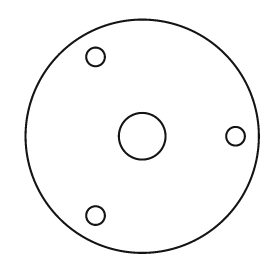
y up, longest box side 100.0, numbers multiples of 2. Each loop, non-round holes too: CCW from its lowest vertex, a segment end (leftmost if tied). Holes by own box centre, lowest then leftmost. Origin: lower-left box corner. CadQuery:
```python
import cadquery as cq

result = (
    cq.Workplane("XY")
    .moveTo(50.0, 50.0)
    .circle(50.0)
    .moveTo(30.0, 16.0)
    .circle(4.0)
    .moveTo(50.0, 50.0)
    .circle(10.0)
    .moveTo(90.0, 50.0)
    .circle(4.0)
    .moveTo(30.0, 84.0)
    .circle(4.0)
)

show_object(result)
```